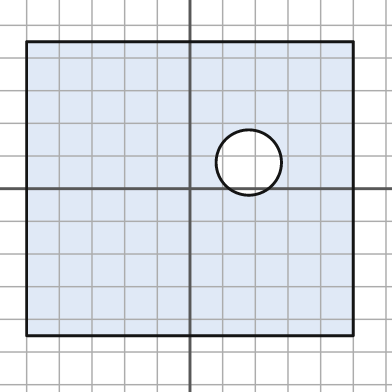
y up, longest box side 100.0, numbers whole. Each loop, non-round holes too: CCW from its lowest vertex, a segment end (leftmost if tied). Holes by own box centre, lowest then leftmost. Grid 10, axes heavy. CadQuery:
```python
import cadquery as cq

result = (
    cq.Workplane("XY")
    .moveTo(-50.0, -45.0)
    .lineTo(50.0, -45.0)
    .lineTo(50.0, 45.0)
    .lineTo(-50.0, 45.0)
    .close()
    .moveTo(18.0, 8.0)
    .circle(10.0)
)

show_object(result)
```